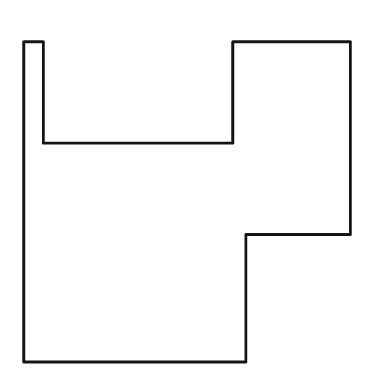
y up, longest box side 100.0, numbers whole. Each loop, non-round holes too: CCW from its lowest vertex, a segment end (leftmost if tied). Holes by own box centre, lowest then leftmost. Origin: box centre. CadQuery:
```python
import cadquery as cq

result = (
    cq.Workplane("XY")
    .moveTo(-50.0, -49.0)
    .lineTo(18.0, -49.0)
    .lineTo(18.0, -10.0)
    .lineTo(50.0, -10.0)
    .lineTo(50.0, 49.0)
    .lineTo(14.0, 49.0)
    .lineTo(14.0, 18.0)
    .lineTo(-44.0, 18.0)
    .lineTo(-44.0, 49.0)
    .lineTo(-50.0, 49.0)
    .close()
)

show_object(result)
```